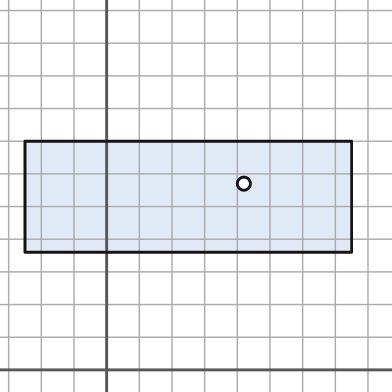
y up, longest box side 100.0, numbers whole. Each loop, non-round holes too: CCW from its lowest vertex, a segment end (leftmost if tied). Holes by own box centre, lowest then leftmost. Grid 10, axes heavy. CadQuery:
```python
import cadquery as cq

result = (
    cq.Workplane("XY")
    .moveTo(-25.0, 36.0)
    .lineTo(75.0, 36.0)
    .lineTo(75.0, 70.0)
    .lineTo(-25.0, 70.0)
    .close()
    .moveTo(42.0, 57.0)
    .circle(2.0)
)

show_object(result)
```